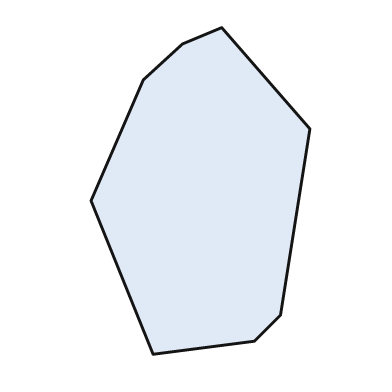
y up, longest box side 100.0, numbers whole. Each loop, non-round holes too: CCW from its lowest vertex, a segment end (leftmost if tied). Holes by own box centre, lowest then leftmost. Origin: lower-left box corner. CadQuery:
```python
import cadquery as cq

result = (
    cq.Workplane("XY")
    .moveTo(19.0, 0.0)
    .lineTo(50.0, 4.0)
    .lineTo(58.0, 12.0)
    .lineTo(67.0, 69.0)
    .lineTo(40.0, 100.0)
    .lineTo(28.0, 95.0)
    .lineTo(16.0, 84.0)
    .lineTo(0.0, 47.0)
    .close()
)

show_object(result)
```